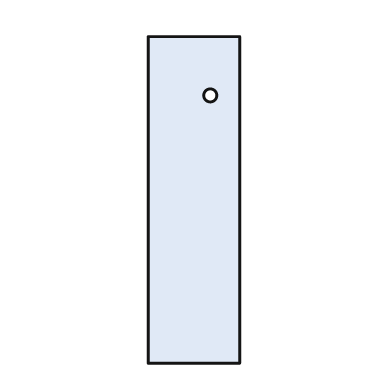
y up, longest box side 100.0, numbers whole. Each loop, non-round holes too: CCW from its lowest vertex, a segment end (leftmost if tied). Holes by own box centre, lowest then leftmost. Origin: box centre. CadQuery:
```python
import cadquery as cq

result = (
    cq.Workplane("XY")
    .moveTo(-14.0, -50.0)
    .lineTo(14.0, -50.0)
    .lineTo(14.0, 50.0)
    .lineTo(-14.0, 50.0)
    .close()
    .moveTo(5.0, 32.0)
    .circle(2.0)
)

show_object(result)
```